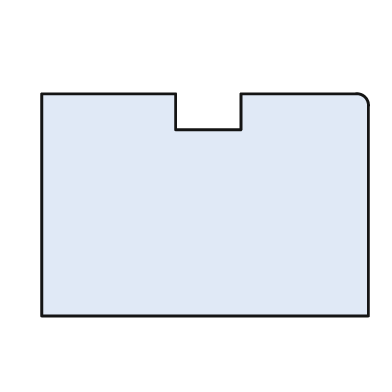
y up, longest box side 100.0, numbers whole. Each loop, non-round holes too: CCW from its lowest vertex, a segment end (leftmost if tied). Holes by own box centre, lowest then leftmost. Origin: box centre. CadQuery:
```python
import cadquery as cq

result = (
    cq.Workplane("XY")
    .moveTo(-50.0, -34.0)
    .lineTo(50.0, -34.0)
    .lineTo(50.0, 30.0)
    .threePointArc((49.0, 33.0), (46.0, 34.0))
    .lineTo(11.0, 34.0)
    .lineTo(11.0, 23.0)
    .lineTo(-9.0, 23.0)
    .lineTo(-9.0, 34.0)
    .lineTo(-50.0, 34.0)
    .close()
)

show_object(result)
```